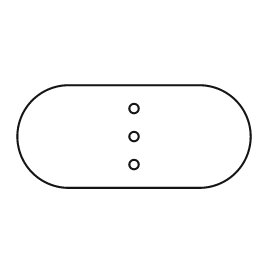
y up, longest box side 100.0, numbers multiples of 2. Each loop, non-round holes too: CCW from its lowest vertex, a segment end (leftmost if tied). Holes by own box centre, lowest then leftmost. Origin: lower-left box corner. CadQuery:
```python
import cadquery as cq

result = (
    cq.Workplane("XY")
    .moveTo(22.0, 0.0)
    .lineTo(78.0, 0.0)
    .threePointArc((100.0, 22.0), (78.0, 44.0))
    .lineTo(22.0, 44.0)
    .threePointArc((0.0, 22.0), (22.0, 0.0))
    .close()
    .moveTo(50.0, 10.0)
    .circle(2.0)
    .moveTo(50.0, 22.0)
    .circle(2.0)
    .moveTo(50.0, 34.0)
    .circle(2.0)
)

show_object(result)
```